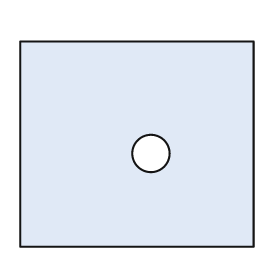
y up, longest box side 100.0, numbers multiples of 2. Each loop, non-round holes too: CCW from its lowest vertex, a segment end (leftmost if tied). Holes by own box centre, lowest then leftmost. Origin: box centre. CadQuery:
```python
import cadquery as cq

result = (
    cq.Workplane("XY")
    .moveTo(-50.0, -44.0)
    .lineTo(50.0, -44.0)
    .lineTo(50.0, 44.0)
    .lineTo(-50.0, 44.0)
    .close()
    .moveTo(6.0, -4.0)
    .circle(8.0)
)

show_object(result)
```